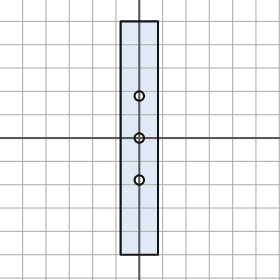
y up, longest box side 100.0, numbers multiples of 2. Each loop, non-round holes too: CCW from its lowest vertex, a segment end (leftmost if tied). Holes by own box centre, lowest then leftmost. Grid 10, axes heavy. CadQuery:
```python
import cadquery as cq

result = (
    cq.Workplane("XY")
    .moveTo(-8.0, -50.0)
    .lineTo(8.0, -50.0)
    .lineTo(8.0, 50.0)
    .lineTo(-8.0, 50.0)
    .close()
    .moveTo(0.0, -18.0)
    .circle(2.0)
    .moveTo(0.0, 0.0)
    .circle(2.0)
    .moveTo(0.0, 18.0)
    .circle(2.0)
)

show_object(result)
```